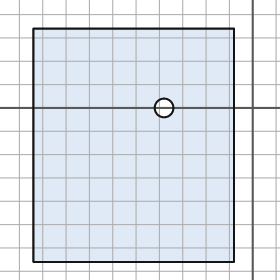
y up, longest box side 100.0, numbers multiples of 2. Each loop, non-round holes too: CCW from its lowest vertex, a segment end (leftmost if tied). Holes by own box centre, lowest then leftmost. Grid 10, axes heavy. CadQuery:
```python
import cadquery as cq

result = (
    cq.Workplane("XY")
    .moveTo(-94.0, -66.0)
    .lineTo(-8.0, -66.0)
    .lineTo(-8.0, 34.0)
    .lineTo(-94.0, 34.0)
    .close()
    .moveTo(-38.0, 0.0)
    .circle(4.0)
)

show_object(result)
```